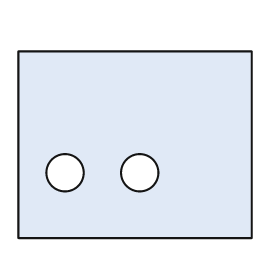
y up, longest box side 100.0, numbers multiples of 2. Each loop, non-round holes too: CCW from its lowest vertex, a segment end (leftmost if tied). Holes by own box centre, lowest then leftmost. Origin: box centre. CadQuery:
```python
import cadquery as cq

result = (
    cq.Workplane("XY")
    .moveTo(-50.0, -40.0)
    .lineTo(50.0, -40.0)
    .lineTo(50.0, 40.0)
    .lineTo(-50.0, 40.0)
    .close()
    .moveTo(-30.0, -12.0)
    .circle(8.0)
    .moveTo(2.0, -12.0)
    .circle(8.0)
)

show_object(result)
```